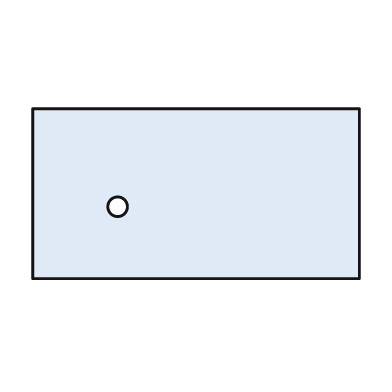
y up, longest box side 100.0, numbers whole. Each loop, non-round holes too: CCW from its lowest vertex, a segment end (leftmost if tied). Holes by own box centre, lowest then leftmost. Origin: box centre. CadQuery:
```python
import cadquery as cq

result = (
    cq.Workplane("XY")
    .moveTo(-50.0, -26.0)
    .lineTo(50.0, -26.0)
    .lineTo(50.0, 26.0)
    .lineTo(-50.0, 26.0)
    .close()
    .moveTo(-24.0, -4.0)
    .circle(3.0)
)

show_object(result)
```